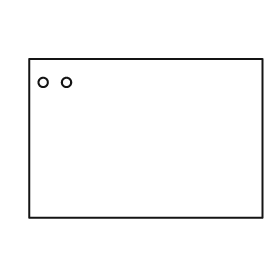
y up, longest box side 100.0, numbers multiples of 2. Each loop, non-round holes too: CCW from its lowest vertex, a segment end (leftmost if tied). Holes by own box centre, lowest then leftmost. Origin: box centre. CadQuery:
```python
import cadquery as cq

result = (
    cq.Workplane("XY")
    .moveTo(-50.0, -34.0)
    .lineTo(50.0, -34.0)
    .lineTo(50.0, 34.0)
    .lineTo(-50.0, 34.0)
    .close()
    .moveTo(-44.0, 24.0)
    .circle(2.0)
    .moveTo(-34.0, 24.0)
    .circle(2.0)
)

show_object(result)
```